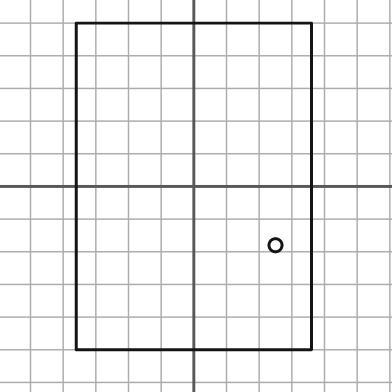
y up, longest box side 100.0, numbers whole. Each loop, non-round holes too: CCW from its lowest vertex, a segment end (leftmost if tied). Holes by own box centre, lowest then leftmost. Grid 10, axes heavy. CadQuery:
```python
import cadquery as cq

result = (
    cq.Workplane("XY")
    .moveTo(-36.0, -50.0)
    .lineTo(36.0, -50.0)
    .lineTo(36.0, 50.0)
    .lineTo(-36.0, 50.0)
    .close()
    .moveTo(25.0, -18.0)
    .circle(2.0)
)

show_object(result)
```